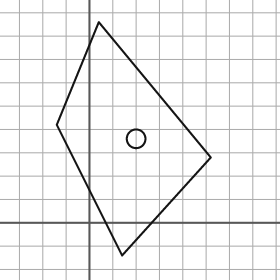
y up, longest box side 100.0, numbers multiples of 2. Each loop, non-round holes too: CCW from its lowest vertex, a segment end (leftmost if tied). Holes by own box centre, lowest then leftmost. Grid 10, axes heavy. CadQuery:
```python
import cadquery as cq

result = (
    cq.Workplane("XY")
    .moveTo(14.0, -14.0)
    .lineTo(52.0, 28.0)
    .lineTo(4.0, 86.0)
    .lineTo(-14.0, 42.0)
    .close()
    .moveTo(20.0, 36.0)
    .circle(4.0)
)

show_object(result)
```